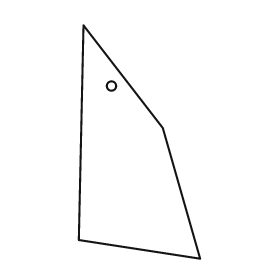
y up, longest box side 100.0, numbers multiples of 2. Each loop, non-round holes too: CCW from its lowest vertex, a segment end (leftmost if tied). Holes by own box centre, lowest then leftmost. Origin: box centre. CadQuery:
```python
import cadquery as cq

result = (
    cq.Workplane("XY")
    .moveTo(26.0, -50.0)
    .lineTo(10.0, 6.0)
    .lineTo(-24.0, 50.0)
    .lineTo(-26.0, -42.0)
    .close()
    .moveTo(-12.0, 24.0)
    .circle(2.0)
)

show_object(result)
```